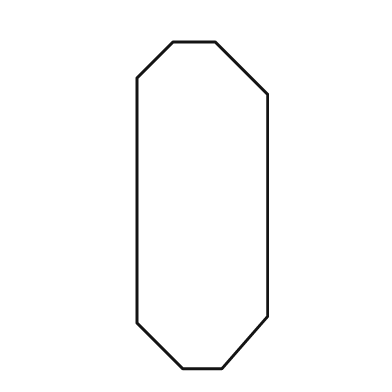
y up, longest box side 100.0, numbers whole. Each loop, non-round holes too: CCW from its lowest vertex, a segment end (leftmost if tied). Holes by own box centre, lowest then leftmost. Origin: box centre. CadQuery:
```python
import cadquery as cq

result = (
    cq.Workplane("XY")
    .moveTo(-6.0, -50.0)
    .lineTo(6.0, -50.0)
    .lineTo(20.0, -34.0)
    .lineTo(20.0, 34.0)
    .lineTo(4.0, 50.0)
    .lineTo(-9.0, 50.0)
    .lineTo(-20.0, 39.0)
    .lineTo(-20.0, -36.0)
    .close()
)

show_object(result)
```